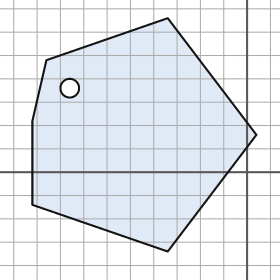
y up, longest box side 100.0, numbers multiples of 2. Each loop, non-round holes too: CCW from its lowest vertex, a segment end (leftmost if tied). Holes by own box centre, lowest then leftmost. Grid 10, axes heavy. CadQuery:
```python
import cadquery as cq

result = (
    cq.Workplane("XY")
    .moveTo(-34.0, -34.0)
    .lineTo(4.0, 16.0)
    .lineTo(-34.0, 66.0)
    .lineTo(-86.0, 48.0)
    .lineTo(-92.0, 22.0)
    .lineTo(-92.0, -14.0)
    .close()
    .moveTo(-76.0, 36.0)
    .circle(4.0)
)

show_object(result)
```